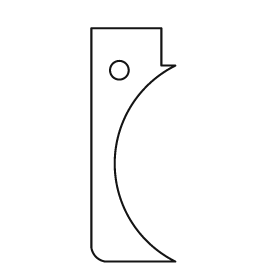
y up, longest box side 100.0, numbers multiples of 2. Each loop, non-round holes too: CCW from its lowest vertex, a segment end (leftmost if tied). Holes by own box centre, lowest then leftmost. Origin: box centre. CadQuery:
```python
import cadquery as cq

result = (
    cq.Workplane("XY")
    .moveTo(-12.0, -50.0)
    .lineTo(18.0, -50.0)
    .threePointArc((-8.0, -8.0), (18.0, 34.0))
    .lineTo(12.0, 34.0)
    .lineTo(12.0, 50.0)
    .lineTo(-18.0, 50.0)
    .lineTo(-18.0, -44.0)
    .threePointArc((-16.0, -48.0), (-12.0, -50.0))
    .close()
    .moveTo(-6.0, 32.0)
    .circle(4.0)
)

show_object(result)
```